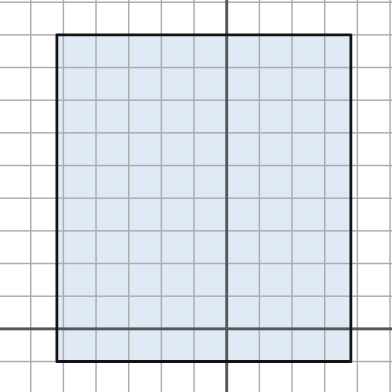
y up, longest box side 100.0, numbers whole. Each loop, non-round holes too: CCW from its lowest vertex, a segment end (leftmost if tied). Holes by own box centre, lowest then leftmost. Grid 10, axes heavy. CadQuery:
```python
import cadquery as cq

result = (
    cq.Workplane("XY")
    .moveTo(-52.0, -10.0)
    .lineTo(38.0, -10.0)
    .lineTo(38.0, 90.0)
    .lineTo(-52.0, 90.0)
    .close()
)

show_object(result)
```